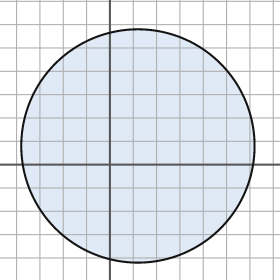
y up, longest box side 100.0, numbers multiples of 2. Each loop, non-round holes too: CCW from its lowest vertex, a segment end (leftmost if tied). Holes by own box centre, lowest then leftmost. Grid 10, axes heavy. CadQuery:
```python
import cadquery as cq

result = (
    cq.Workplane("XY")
    .moveTo(12.0, 8.0)
    .circle(50.0)
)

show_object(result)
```